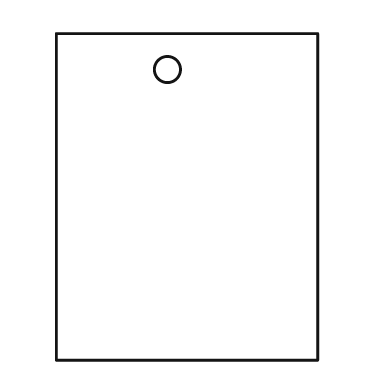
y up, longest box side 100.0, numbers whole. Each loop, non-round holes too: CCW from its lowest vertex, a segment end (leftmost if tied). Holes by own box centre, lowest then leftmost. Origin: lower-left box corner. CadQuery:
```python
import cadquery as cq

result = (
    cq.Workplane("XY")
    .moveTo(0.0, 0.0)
    .lineTo(80.0, 0.0)
    .lineTo(80.0, 100.0)
    .lineTo(0.0, 100.0)
    .close()
    .moveTo(34.0, 89.0)
    .circle(4.0)
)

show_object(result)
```